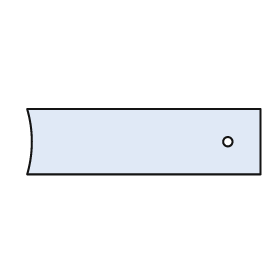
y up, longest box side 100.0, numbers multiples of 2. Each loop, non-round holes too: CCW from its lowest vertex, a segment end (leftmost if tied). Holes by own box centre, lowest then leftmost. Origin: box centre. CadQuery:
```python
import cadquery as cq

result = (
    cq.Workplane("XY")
    .moveTo(-50.0, -14.0)
    .lineTo(50.0, -14.0)
    .lineTo(50.0, 14.0)
    .lineTo(-50.0, 14.0)
    .threePointArc((-48.0, 0.0), (-50.0, -14.0))
    .close()
    .moveTo(36.0, 0.0)
    .circle(2.0)
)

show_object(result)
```